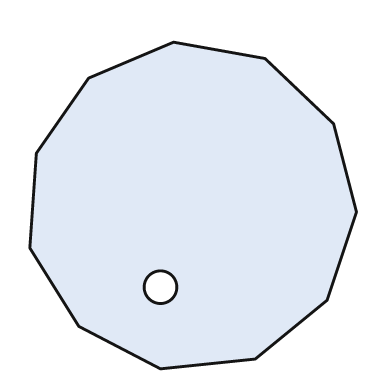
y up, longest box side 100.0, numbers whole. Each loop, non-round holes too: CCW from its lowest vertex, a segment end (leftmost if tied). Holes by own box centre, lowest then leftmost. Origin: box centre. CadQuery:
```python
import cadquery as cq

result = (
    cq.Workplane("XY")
    .moveTo(-10.0, -50.0)
    .lineTo(19.0, -47.0)
    .lineTo(41.0, -29.0)
    .lineTo(50.0, -2.0)
    .lineTo(43.0, 25.0)
    .lineTo(22.0, 45.0)
    .lineTo(-6.0, 50.0)
    .lineTo(-32.0, 39.0)
    .lineTo(-48.0, 16.0)
    .lineTo(-50.0, -13.0)
    .lineTo(-35.0, -37.0)
    .close()
    .moveTo(-10.0, -25.0)
    .circle(5.0)
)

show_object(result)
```